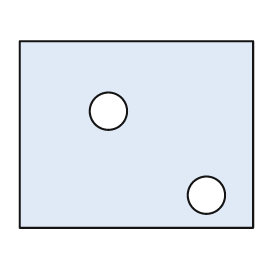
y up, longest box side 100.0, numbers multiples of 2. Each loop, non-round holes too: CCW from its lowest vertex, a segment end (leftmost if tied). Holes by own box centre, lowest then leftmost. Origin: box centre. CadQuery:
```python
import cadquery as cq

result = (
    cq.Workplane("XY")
    .moveTo(-50.0, -40.0)
    .lineTo(50.0, -40.0)
    .lineTo(50.0, 40.0)
    .lineTo(-50.0, 40.0)
    .close()
    .moveTo(30.0, -26.0)
    .circle(8.0)
    .moveTo(-12.0, 10.0)
    .circle(8.0)
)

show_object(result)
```